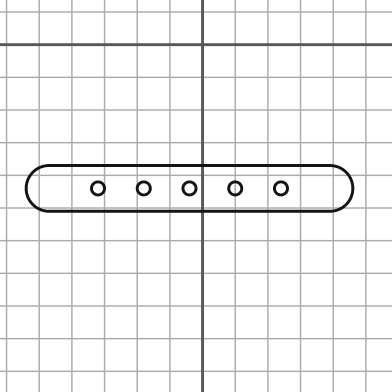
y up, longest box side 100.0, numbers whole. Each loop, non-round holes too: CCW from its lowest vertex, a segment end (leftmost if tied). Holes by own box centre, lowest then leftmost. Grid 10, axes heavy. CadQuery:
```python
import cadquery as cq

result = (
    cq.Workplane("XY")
    .moveTo(-47.0, -51.0)
    .lineTo(39.0, -51.0)
    .threePointArc((46.0, -44.0), (39.0, -37.0))
    .lineTo(-47.0, -37.0)
    .threePointArc((-54.0, -44.0), (-47.0, -51.0))
    .close()
    .moveTo(-32.0, -44.0)
    .circle(2.0)
    .moveTo(-18.0, -44.0)
    .circle(2.0)
    .moveTo(-4.0, -44.0)
    .circle(2.0)
    .moveTo(10.0, -44.0)
    .circle(2.0)
    .moveTo(24.0, -44.0)
    .circle(2.0)
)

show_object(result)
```